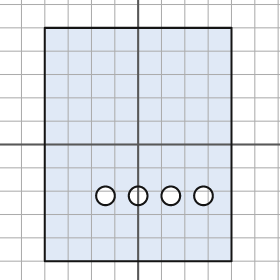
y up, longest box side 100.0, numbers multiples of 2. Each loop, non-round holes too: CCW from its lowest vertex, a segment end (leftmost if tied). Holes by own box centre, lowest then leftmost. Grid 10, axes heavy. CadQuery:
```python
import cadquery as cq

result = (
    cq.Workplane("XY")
    .moveTo(-40.0, -50.0)
    .lineTo(40.0, -50.0)
    .lineTo(40.0, 50.0)
    .lineTo(-40.0, 50.0)
    .close()
    .moveTo(-14.0, -22.0)
    .circle(4.0)
    .moveTo(0.0, -22.0)
    .circle(4.0)
    .moveTo(14.0, -22.0)
    .circle(4.0)
    .moveTo(28.0, -22.0)
    .circle(4.0)
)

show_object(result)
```